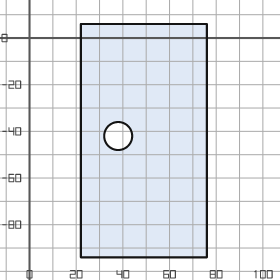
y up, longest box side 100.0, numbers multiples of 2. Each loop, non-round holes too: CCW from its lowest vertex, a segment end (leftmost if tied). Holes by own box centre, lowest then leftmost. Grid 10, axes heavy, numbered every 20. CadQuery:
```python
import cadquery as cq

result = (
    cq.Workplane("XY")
    .moveTo(22.0, -94.0)
    .lineTo(76.0, -94.0)
    .lineTo(76.0, 6.0)
    .lineTo(22.0, 6.0)
    .close()
    .moveTo(38.0, -42.0)
    .circle(6.0)
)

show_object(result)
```